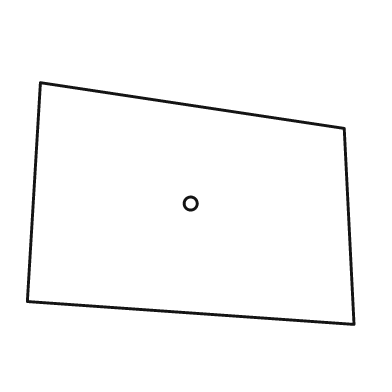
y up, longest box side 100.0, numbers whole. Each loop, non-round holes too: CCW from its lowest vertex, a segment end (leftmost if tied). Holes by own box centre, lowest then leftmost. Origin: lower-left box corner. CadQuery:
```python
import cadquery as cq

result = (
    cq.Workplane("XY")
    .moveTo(100.0, 0.0)
    .lineTo(97.0, 60.0)
    .lineTo(4.0, 74.0)
    .lineTo(0.0, 7.0)
    .close()
    .moveTo(50.0, 37.0)
    .circle(2.0)
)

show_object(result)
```